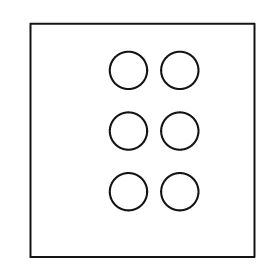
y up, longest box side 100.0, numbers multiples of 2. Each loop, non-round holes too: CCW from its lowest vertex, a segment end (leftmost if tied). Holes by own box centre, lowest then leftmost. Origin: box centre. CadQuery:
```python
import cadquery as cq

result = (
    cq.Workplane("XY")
    .moveTo(-48.0, -50.0)
    .lineTo(48.0, -50.0)
    .lineTo(48.0, 50.0)
    .lineTo(-48.0, 50.0)
    .close()
    .moveTo(-6.0, -22.0)
    .circle(8.0)
    .moveTo(16.0, -22.0)
    .circle(8.0)
    .moveTo(-6.0, 4.0)
    .circle(8.0)
    .moveTo(16.0, 4.0)
    .circle(8.0)
    .moveTo(-6.0, 30.0)
    .circle(8.0)
    .moveTo(16.0, 30.0)
    .circle(8.0)
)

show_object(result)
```